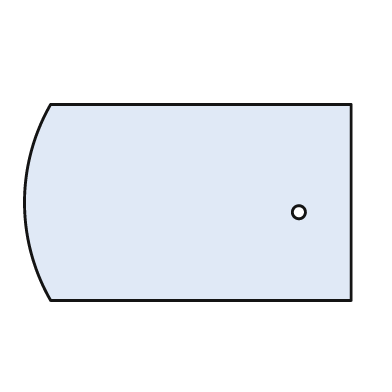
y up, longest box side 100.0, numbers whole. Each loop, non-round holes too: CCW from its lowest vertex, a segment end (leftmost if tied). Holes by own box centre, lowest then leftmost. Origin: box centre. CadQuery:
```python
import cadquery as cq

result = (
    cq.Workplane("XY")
    .moveTo(-42.0, -30.0)
    .lineTo(50.0, -30.0)
    .lineTo(50.0, 30.0)
    .lineTo(-42.0, 30.0)
    .threePointArc((-50.0, 0.0), (-42.0, -30.0))
    .close()
    .moveTo(34.0, -3.0)
    .circle(2.0)
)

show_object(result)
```